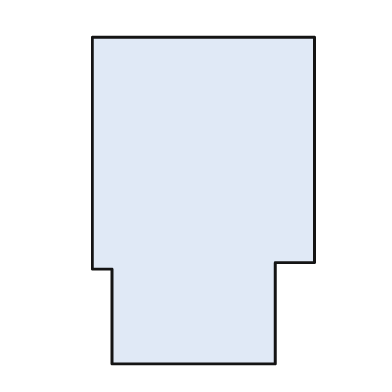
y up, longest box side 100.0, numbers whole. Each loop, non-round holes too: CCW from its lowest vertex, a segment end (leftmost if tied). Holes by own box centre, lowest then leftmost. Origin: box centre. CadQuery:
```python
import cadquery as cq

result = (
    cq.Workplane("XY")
    .moveTo(-28.0, -50.0)
    .lineTo(22.0, -50.0)
    .lineTo(22.0, -19.0)
    .lineTo(34.0, -19.0)
    .lineTo(34.0, 50.0)
    .lineTo(-34.0, 50.0)
    .lineTo(-34.0, -21.0)
    .lineTo(-28.0, -21.0)
    .close()
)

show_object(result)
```